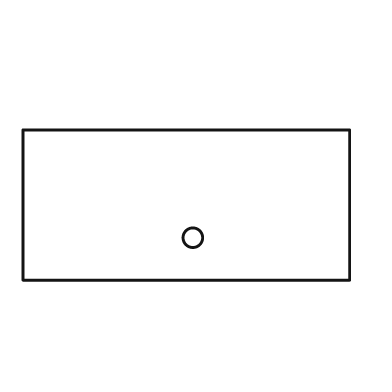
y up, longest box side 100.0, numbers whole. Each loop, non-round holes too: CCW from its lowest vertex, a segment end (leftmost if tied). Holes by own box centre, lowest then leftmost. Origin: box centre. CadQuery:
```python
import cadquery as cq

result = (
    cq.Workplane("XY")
    .moveTo(-50.0, -23.0)
    .lineTo(50.0, -23.0)
    .lineTo(50.0, 23.0)
    .lineTo(-50.0, 23.0)
    .close()
    .moveTo(2.0, -10.0)
    .circle(3.0)
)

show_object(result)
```